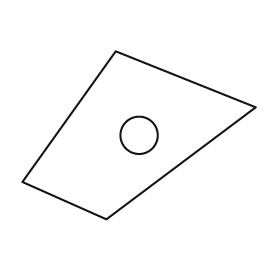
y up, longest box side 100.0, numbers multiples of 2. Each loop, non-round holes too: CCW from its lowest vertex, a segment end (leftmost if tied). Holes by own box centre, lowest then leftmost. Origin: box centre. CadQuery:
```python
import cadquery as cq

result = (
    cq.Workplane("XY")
    .moveTo(-14.0, -36.0)
    .lineTo(50.0, 12.0)
    .lineTo(-10.0, 36.0)
    .lineTo(-50.0, -20.0)
    .close()
    .moveTo(0.0, 0.0)
    .circle(8.0)
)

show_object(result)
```